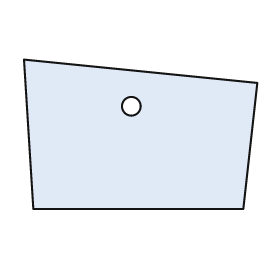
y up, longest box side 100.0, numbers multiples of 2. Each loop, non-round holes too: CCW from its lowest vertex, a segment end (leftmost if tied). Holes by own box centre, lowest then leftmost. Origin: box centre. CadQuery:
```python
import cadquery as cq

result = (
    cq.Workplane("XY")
    .moveTo(-46.0, -32.0)
    .lineTo(44.0, -32.0)
    .lineTo(50.0, 22.0)
    .lineTo(-50.0, 32.0)
    .close()
    .moveTo(-4.0, 12.0)
    .circle(4.0)
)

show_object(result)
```